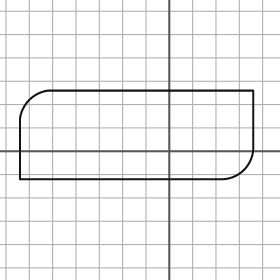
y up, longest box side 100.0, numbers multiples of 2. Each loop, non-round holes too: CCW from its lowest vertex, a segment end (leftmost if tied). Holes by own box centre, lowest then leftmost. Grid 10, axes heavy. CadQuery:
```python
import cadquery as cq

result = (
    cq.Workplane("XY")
    .moveTo(-64.0, -12.0)
    .lineTo(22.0, -12.0)
    .threePointArc((32.0, -8.0), (36.0, 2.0))
    .lineTo(36.0, 26.0)
    .lineTo(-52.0, 26.0)
    .threePointArc((-60.0, 22.0), (-64.0, 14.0))
    .close()
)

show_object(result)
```